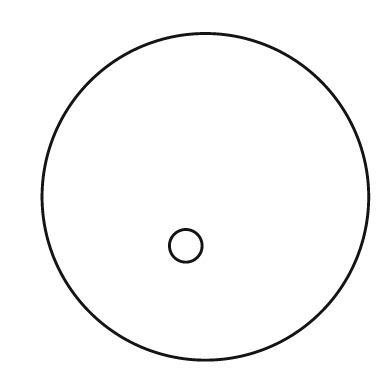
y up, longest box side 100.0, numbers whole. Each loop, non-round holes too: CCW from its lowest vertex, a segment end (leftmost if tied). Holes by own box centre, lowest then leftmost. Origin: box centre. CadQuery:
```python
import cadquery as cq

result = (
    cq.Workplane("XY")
    .moveTo(0.0, 0.0)
    .circle(50.0)
    .moveTo(-6.0, -15.0)
    .circle(5.0)
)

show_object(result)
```